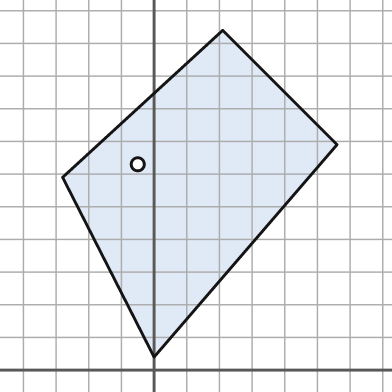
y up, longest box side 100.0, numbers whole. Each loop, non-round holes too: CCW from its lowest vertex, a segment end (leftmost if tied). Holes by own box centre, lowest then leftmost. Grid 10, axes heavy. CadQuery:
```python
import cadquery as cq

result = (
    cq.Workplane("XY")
    .moveTo(0.0, 4.0)
    .lineTo(56.0, 69.0)
    .lineTo(21.0, 104.0)
    .lineTo(-28.0, 59.0)
    .close()
    .moveTo(-5.0, 63.0)
    .circle(2.0)
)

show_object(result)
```